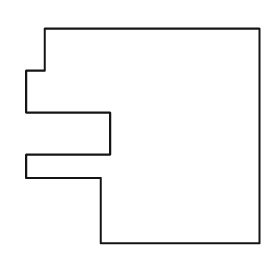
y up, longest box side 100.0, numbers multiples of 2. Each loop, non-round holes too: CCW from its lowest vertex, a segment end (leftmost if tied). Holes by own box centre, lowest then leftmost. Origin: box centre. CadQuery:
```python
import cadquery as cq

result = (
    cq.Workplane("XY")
    .moveTo(-18.0, -46.0)
    .lineTo(50.0, -46.0)
    .lineTo(50.0, 46.0)
    .lineTo(-42.0, 46.0)
    .lineTo(-42.0, 28.0)
    .lineTo(-50.0, 28.0)
    .lineTo(-50.0, 10.0)
    .lineTo(-14.0, 10.0)
    .lineTo(-14.0, -8.0)
    .lineTo(-50.0, -8.0)
    .lineTo(-50.0, -18.0)
    .lineTo(-18.0, -18.0)
    .close()
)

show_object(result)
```